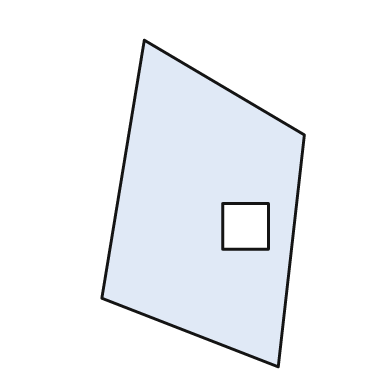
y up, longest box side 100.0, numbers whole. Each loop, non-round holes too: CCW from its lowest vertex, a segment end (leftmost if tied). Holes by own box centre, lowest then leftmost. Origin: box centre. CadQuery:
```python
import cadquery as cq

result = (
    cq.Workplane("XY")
    .moveTo(23.0, -50.0)
    .lineTo(31.0, 21.0)
    .lineTo(-18.0, 50.0)
    .lineTo(-31.0, -29.0)
    .close()
    .moveTo(6.0, -14.0)
    .lineTo(20.0, -14.0)
    .lineTo(20.0, 0.0)
    .lineTo(6.0, 0.0)
    .close()
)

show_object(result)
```